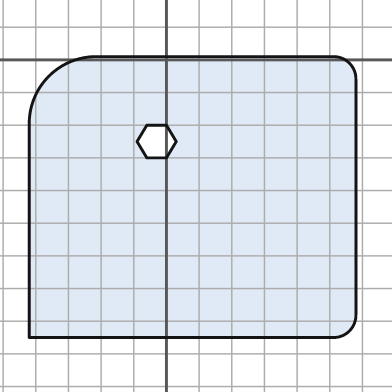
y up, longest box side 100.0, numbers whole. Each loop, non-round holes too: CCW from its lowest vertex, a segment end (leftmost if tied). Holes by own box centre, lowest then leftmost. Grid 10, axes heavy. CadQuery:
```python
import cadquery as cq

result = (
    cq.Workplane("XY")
    .moveTo(-42.0, -85.0)
    .lineTo(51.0, -85.0)
    .threePointArc((56.0, -83.0), (58.0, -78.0))
    .lineTo(58.0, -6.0)
    .threePointArc((56.0, -1.0), (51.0, 1.0))
    .lineTo(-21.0, 1.0)
    .threePointArc((-36.0, -5.0), (-42.0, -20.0))
    .close()
    .moveTo(-6.0, -30.0)
    .lineTo(0.0, -30.0)
    .lineTo(3.0, -25.0)
    .lineTo(0.0, -20.0)
    .lineTo(-6.0, -20.0)
    .lineTo(-9.0, -25.0)
    .close()
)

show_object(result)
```